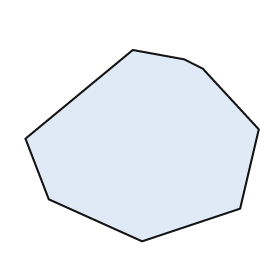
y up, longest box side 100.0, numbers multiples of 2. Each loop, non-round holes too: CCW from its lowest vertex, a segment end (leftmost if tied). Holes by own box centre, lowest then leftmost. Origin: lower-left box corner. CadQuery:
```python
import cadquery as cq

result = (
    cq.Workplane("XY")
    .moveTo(50.0, 0.0)
    .lineTo(92.0, 14.0)
    .lineTo(100.0, 48.0)
    .lineTo(76.0, 74.0)
    .lineTo(68.0, 78.0)
    .lineTo(46.0, 82.0)
    .lineTo(0.0, 44.0)
    .lineTo(10.0, 18.0)
    .close()
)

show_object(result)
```